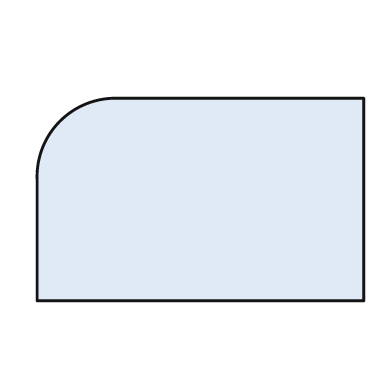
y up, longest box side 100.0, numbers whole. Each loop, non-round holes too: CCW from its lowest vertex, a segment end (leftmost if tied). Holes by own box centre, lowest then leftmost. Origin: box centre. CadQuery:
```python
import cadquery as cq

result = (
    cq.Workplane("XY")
    .moveTo(-50.0, -31.0)
    .lineTo(50.0, -31.0)
    .lineTo(50.0, 31.0)
    .lineTo(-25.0, 31.0)
    .threePointArc((-43.0, 24.0), (-50.0, 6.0))
    .close()
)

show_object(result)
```